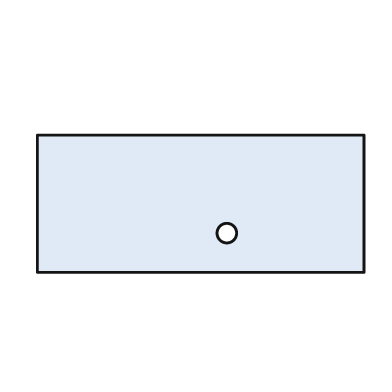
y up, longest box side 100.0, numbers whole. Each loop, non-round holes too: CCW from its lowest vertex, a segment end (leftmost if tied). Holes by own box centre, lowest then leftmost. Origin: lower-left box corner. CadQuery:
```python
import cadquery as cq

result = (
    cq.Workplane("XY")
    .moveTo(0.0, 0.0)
    .lineTo(100.0, 0.0)
    .lineTo(100.0, 42.0)
    .lineTo(0.0, 42.0)
    .close()
    .moveTo(58.0, 12.0)
    .circle(3.0)
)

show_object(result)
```